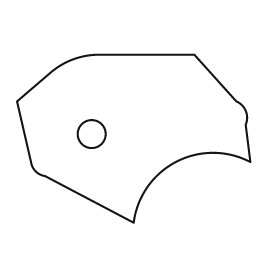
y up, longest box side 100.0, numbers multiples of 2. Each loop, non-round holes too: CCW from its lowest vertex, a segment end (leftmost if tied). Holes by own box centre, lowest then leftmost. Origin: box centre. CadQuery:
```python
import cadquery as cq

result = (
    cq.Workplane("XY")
    .moveTo(0.0, -36.0)
    .threePointArc((18.0, -10.0), (50.0, -10.0))
    .lineTo(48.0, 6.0)
    .threePointArc((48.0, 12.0), (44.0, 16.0))
    .lineTo(26.0, 36.0)
    .lineTo(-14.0, 36.0)
    .threePointArc((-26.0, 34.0), (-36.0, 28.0))
    .lineTo(-50.0, 16.0)
    .lineTo(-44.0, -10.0)
    .threePointArc((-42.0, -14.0), (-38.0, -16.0))
    .close()
    .moveTo(-18.0, 2.0)
    .circle(6.0)
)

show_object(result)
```